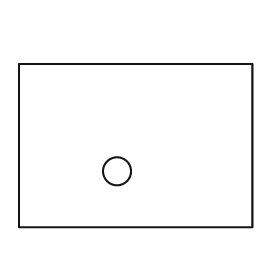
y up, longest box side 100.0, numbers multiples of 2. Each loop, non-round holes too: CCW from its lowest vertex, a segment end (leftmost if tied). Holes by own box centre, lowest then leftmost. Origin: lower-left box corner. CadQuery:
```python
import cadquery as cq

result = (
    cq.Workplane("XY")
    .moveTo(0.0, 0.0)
    .lineTo(100.0, 0.0)
    .lineTo(100.0, 70.0)
    .lineTo(0.0, 70.0)
    .close()
    .moveTo(42.0, 24.0)
    .circle(6.0)
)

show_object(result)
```